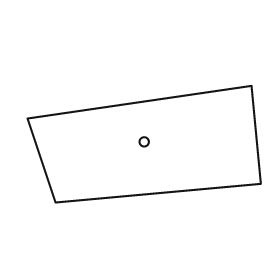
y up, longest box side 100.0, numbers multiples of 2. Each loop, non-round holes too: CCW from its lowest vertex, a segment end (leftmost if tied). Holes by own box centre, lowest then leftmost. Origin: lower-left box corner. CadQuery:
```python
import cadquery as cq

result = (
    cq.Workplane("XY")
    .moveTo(12.0, 0.0)
    .lineTo(100.0, 8.0)
    .lineTo(96.0, 50.0)
    .lineTo(0.0, 36.0)
    .close()
    .moveTo(50.0, 26.0)
    .circle(2.0)
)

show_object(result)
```